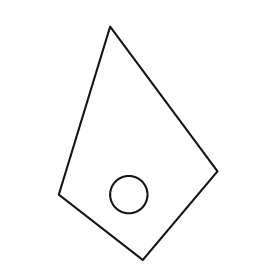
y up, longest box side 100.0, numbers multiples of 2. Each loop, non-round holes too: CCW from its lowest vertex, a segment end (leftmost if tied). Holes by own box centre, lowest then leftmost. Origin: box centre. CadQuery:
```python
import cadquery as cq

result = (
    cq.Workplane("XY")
    .moveTo(2.0, -50.0)
    .lineTo(34.0, -12.0)
    .lineTo(-12.0, 50.0)
    .lineTo(-34.0, -22.0)
    .close()
    .moveTo(-4.0, -22.0)
    .circle(8.0)
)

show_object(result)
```